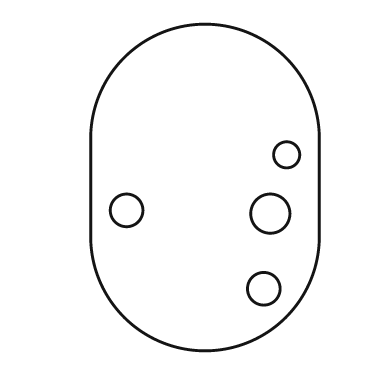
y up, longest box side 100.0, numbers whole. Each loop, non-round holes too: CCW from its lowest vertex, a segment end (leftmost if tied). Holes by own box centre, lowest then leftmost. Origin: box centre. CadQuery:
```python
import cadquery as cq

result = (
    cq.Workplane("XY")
    .moveTo(-35.0, -15.0)
    .threePointArc((0.0, -50.0), (35.0, -15.0))
    .lineTo(35.0, 15.0)
    .threePointArc((0.0, 50.0), (-35.0, 15.0))
    .close()
    .moveTo(18.0, -31.0)
    .circle(5.0)
    .moveTo(20.0, -8.0)
    .circle(6.0)
    .moveTo(-24.0, -7.0)
    .circle(5.0)
    .moveTo(25.0, 10.0)
    .circle(4.0)
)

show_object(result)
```